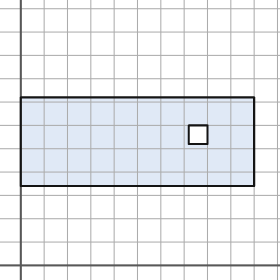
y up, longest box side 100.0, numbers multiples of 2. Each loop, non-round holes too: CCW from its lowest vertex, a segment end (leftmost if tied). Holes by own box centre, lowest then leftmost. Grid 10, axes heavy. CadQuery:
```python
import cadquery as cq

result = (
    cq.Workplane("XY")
    .moveTo(0.0, 34.0)
    .lineTo(100.0, 34.0)
    .lineTo(100.0, 72.0)
    .lineTo(0.0, 72.0)
    .close()
    .moveTo(72.0, 52.0)
    .lineTo(80.0, 52.0)
    .lineTo(80.0, 60.0)
    .lineTo(72.0, 60.0)
    .close()
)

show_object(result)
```